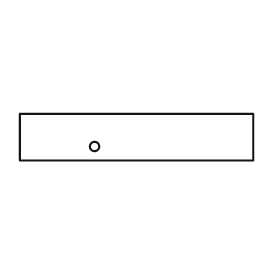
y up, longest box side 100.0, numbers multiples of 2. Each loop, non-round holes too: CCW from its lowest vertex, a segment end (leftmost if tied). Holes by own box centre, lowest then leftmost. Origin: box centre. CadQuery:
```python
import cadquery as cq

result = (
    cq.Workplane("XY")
    .moveTo(-50.0, -10.0)
    .lineTo(50.0, -10.0)
    .lineTo(50.0, 10.0)
    .lineTo(-50.0, 10.0)
    .close()
    .moveTo(-18.0, -4.0)
    .circle(2.0)
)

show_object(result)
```